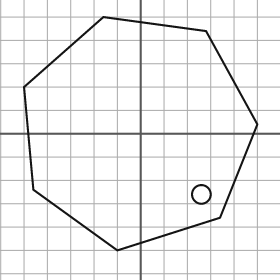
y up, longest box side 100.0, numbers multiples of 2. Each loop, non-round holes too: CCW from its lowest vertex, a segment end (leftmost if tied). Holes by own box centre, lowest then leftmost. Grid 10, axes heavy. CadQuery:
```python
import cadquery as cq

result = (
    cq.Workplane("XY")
    .moveTo(-10.0, -50.0)
    .lineTo(34.0, -36.0)
    .lineTo(50.0, 4.0)
    .lineTo(28.0, 44.0)
    .lineTo(-16.0, 50.0)
    .lineTo(-50.0, 20.0)
    .lineTo(-46.0, -24.0)
    .close()
    .moveTo(26.0, -26.0)
    .circle(4.0)
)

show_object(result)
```